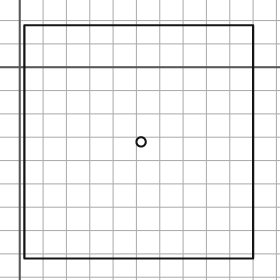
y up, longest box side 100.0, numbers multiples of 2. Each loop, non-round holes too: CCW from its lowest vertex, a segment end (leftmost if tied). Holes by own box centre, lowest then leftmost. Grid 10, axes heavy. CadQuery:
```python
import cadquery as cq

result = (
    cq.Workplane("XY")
    .moveTo(2.0, -82.0)
    .lineTo(100.0, -82.0)
    .lineTo(100.0, 18.0)
    .lineTo(2.0, 18.0)
    .close()
    .moveTo(52.0, -32.0)
    .circle(2.0)
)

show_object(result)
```